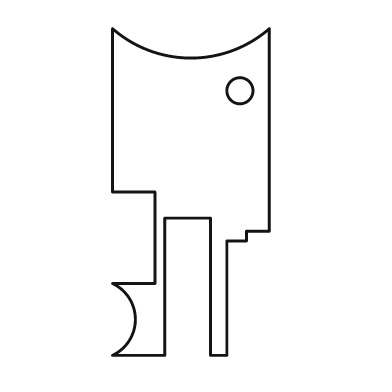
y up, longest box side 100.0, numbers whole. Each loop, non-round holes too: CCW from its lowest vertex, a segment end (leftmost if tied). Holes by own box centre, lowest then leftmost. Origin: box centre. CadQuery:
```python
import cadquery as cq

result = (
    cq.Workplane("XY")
    .moveTo(-24.0, -50.0)
    .lineTo(-8.0, -50.0)
    .lineTo(-8.0, -8.0)
    .lineTo(6.0, -8.0)
    .lineTo(6.0, -50.0)
    .lineTo(11.0, -50.0)
    .lineTo(11.0, -15.0)
    .lineTo(17.0, -15.0)
    .lineTo(17.0, -12.0)
    .lineTo(24.0, -12.0)
    .lineTo(24.0, 50.0)
    .threePointArc((0.0, 41.0), (-24.0, 50.0))
    .lineTo(-24.0, 0.0)
    .lineTo(-11.0, 0.0)
    .lineTo(-11.0, -28.0)
    .lineTo(-24.0, -28.0)
    .threePointArc((-17.0, -39.0), (-24.0, -50.0))
    .close()
    .moveTo(15.0, 31.0)
    .circle(4.0)
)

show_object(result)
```